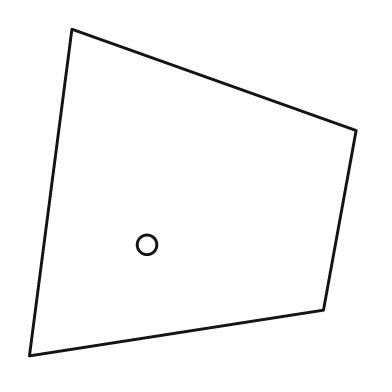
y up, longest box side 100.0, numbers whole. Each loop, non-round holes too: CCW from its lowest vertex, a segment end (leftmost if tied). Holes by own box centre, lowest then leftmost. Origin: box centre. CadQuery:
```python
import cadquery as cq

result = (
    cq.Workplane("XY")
    .moveTo(-50.0, -50.0)
    .lineTo(40.0, -36.0)
    .lineTo(50.0, 19.0)
    .lineTo(-37.0, 50.0)
    .close()
    .moveTo(-14.0, -16.0)
    .circle(3.0)
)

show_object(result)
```